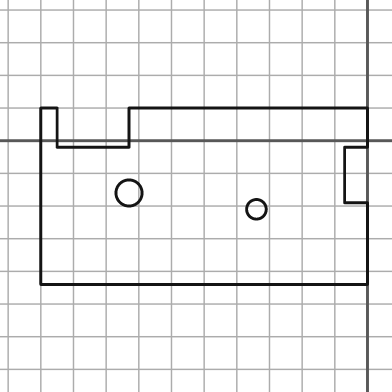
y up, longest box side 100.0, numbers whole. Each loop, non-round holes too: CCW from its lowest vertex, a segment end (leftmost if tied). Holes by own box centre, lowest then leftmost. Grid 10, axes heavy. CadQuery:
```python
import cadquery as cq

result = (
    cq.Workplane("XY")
    .moveTo(-100.0, -44.0)
    .lineTo(0.0, -44.0)
    .lineTo(0.0, -19.0)
    .lineTo(-7.0, -19.0)
    .lineTo(-7.0, -2.0)
    .lineTo(0.0, -2.0)
    .lineTo(0.0, 10.0)
    .lineTo(-73.0, 10.0)
    .lineTo(-73.0, -2.0)
    .lineTo(-95.0, -2.0)
    .lineTo(-95.0, 10.0)
    .lineTo(-100.0, 10.0)
    .close()
    .moveTo(-34.0, -21.0)
    .circle(3.0)
    .moveTo(-73.0, -16.0)
    .circle(4.0)
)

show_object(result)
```